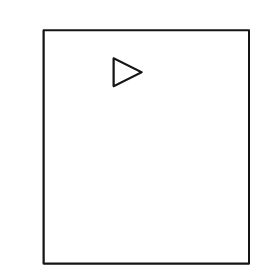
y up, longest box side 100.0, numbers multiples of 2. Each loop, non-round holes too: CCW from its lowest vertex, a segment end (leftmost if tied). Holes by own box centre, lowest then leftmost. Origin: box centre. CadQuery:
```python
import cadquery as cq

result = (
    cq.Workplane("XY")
    .moveTo(-44.0, -50.0)
    .lineTo(44.0, -50.0)
    .lineTo(44.0, 50.0)
    .lineTo(-44.0, 50.0)
    .close()
    .moveTo(-14.0, 26.0)
    .lineTo(-2.0, 32.0)
    .lineTo(-14.0, 38.0)
    .close()
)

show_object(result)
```